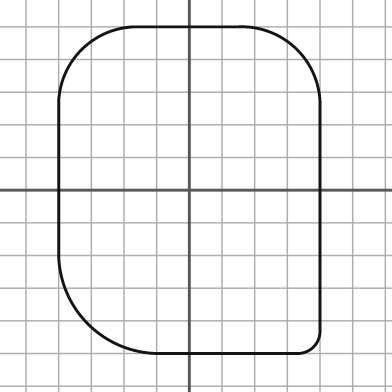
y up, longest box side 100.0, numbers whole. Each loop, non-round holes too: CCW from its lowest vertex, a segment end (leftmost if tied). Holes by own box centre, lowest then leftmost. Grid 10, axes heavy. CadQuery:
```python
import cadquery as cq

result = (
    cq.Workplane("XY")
    .moveTo(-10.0, -50.0)
    .lineTo(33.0, -50.0)
    .threePointArc((38.0, -48.0), (40.0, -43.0))
    .lineTo(40.0, 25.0)
    .threePointArc((33.0, 43.0), (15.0, 50.0))
    .lineTo(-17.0, 50.0)
    .threePointArc((-33.0, 43.0), (-40.0, 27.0))
    .lineTo(-40.0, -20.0)
    .threePointArc((-31.0, -41.0), (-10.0, -50.0))
    .close()
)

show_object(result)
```